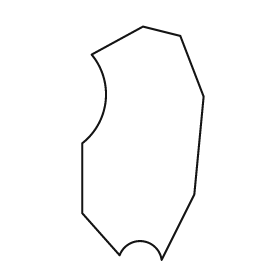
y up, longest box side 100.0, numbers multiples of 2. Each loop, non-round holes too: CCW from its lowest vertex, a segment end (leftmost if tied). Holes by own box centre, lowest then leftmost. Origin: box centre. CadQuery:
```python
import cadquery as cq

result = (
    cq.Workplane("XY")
    .moveTo(8.0, -50.0)
    .lineTo(22.0, -22.0)
    .lineTo(26.0, 20.0)
    .lineTo(16.0, 46.0)
    .lineTo(0.0, 50.0)
    .lineTo(-22.0, 38.0)
    .threePointArc((-16.0, 18.0), (-26.0, 0.0))
    .lineTo(-26.0, -30.0)
    .lineTo(-10.0, -48.0)
    .threePointArc((0.0, -42.0), (8.0, -50.0))
    .close()
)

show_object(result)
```